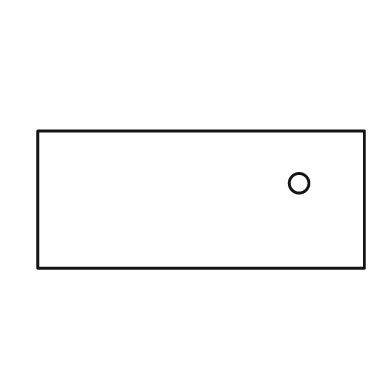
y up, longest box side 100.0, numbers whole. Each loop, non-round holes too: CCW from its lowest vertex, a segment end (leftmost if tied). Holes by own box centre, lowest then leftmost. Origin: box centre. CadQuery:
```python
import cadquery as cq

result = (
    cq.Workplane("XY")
    .moveTo(-50.0, -21.0)
    .lineTo(50.0, -21.0)
    .lineTo(50.0, 21.0)
    .lineTo(-50.0, 21.0)
    .close()
    .moveTo(30.0, 5.0)
    .circle(3.0)
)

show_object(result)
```